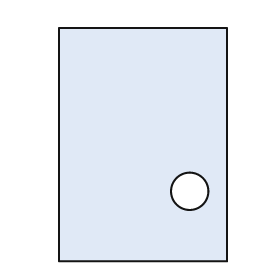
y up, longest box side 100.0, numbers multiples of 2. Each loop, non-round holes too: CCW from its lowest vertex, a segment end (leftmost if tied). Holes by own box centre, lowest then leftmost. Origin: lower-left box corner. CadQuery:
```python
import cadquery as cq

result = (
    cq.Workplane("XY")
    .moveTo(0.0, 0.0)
    .lineTo(72.0, 0.0)
    .lineTo(72.0, 100.0)
    .lineTo(0.0, 100.0)
    .close()
    .moveTo(56.0, 30.0)
    .circle(8.0)
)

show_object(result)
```